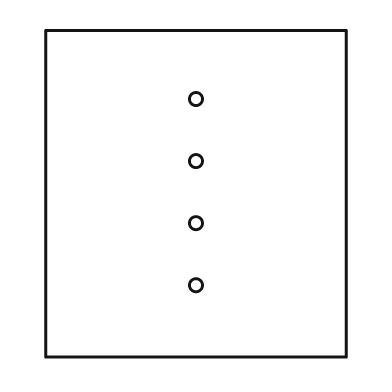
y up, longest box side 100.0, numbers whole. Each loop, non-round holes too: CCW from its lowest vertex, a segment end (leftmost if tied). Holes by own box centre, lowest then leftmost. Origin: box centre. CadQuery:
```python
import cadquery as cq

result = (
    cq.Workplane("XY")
    .moveTo(-46.0, -50.0)
    .lineTo(46.0, -50.0)
    .lineTo(46.0, 50.0)
    .lineTo(-46.0, 50.0)
    .close()
    .moveTo(0.0, -28.0)
    .circle(2.0)
    .moveTo(0.0, -9.0)
    .circle(2.0)
    .moveTo(0.0, 10.0)
    .circle(2.0)
    .moveTo(0.0, 29.0)
    .circle(2.0)
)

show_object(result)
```